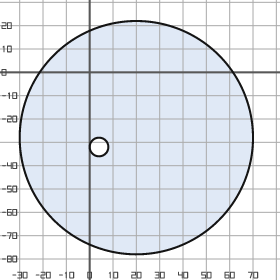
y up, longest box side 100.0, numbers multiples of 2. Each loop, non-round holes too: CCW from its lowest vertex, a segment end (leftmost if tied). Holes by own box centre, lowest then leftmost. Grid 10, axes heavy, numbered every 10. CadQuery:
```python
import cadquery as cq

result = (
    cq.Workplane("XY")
    .moveTo(20.0, -28.0)
    .circle(50.0)
    .moveTo(4.0, -32.0)
    .circle(4.0)
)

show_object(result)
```